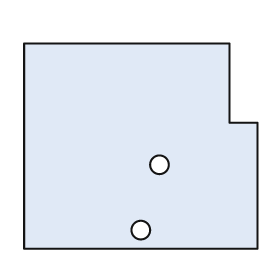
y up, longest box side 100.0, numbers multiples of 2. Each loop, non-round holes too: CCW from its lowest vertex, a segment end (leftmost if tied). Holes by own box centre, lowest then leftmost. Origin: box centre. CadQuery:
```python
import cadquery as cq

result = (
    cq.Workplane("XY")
    .moveTo(-50.0, -44.0)
    .lineTo(50.0, -44.0)
    .lineTo(50.0, 10.0)
    .lineTo(38.0, 10.0)
    .lineTo(38.0, 44.0)
    .lineTo(-50.0, 44.0)
    .close()
    .moveTo(0.0, -36.0)
    .circle(4.0)
    .moveTo(8.0, -8.0)
    .circle(4.0)
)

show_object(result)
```